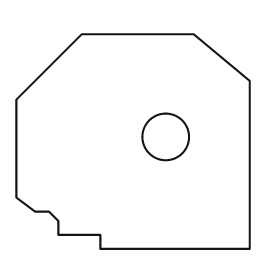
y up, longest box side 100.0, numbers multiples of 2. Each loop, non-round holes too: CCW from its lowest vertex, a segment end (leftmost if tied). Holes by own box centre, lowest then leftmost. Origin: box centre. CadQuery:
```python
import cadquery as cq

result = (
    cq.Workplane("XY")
    .moveTo(-14.0, -46.0)
    .lineTo(50.0, -46.0)
    .lineTo(50.0, 26.0)
    .lineTo(26.0, 46.0)
    .lineTo(-22.0, 46.0)
    .lineTo(-50.0, 18.0)
    .lineTo(-50.0, -24.0)
    .lineTo(-42.0, -30.0)
    .lineTo(-36.0, -30.0)
    .lineTo(-32.0, -34.0)
    .lineTo(-32.0, -40.0)
    .lineTo(-14.0, -40.0)
    .close()
    .moveTo(14.0, 2.0)
    .circle(10.0)
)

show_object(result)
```